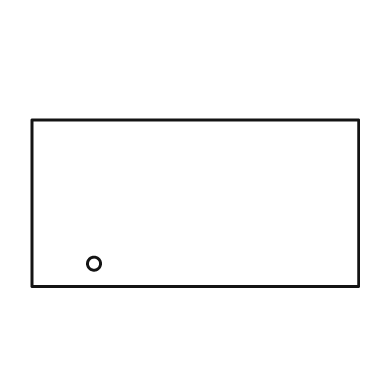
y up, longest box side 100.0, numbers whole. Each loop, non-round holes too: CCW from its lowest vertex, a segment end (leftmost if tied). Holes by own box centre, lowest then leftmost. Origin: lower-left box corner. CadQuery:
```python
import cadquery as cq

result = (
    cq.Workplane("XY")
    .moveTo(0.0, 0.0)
    .lineTo(100.0, 0.0)
    .lineTo(100.0, 51.0)
    .lineTo(0.0, 51.0)
    .close()
    .moveTo(19.0, 7.0)
    .circle(2.0)
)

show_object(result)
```